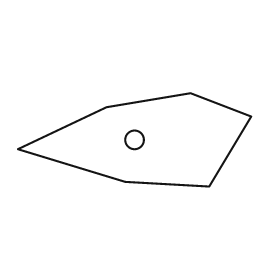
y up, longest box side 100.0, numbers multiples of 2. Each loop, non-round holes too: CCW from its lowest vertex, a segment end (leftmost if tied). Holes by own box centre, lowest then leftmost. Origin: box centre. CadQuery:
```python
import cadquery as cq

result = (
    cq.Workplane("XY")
    .moveTo(32.0, -20.0)
    .lineTo(50.0, 10.0)
    .lineTo(24.0, 20.0)
    .lineTo(-12.0, 14.0)
    .lineTo(-50.0, -4.0)
    .lineTo(-4.0, -18.0)
    .close()
    .moveTo(0.0, 0.0)
    .circle(4.0)
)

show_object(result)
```